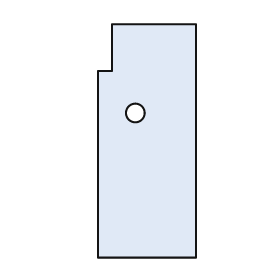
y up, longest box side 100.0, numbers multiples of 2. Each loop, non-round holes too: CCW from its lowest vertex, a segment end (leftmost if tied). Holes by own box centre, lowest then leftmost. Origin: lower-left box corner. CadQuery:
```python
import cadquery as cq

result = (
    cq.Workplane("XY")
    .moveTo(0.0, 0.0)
    .lineTo(42.0, 0.0)
    .lineTo(42.0, 100.0)
    .lineTo(6.0, 100.0)
    .lineTo(6.0, 80.0)
    .lineTo(0.0, 80.0)
    .close()
    .moveTo(16.0, 62.0)
    .circle(4.0)
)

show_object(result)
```